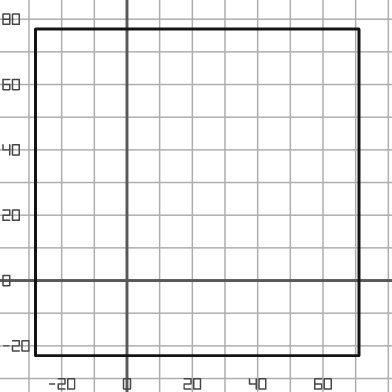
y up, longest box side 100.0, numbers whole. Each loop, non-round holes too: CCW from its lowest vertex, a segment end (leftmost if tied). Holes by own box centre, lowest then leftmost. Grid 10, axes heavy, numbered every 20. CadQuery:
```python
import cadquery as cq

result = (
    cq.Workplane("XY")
    .moveTo(-28.0, -23.0)
    .lineTo(71.0, -23.0)
    .lineTo(71.0, 77.0)
    .lineTo(-28.0, 77.0)
    .close()
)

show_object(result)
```